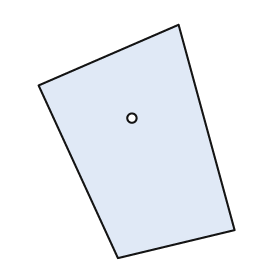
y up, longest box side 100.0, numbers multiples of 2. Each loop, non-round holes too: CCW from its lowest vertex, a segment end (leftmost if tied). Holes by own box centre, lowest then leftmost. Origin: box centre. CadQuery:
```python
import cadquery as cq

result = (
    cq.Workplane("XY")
    .moveTo(-8.0, -50.0)
    .lineTo(42.0, -38.0)
    .lineTo(18.0, 50.0)
    .lineTo(-42.0, 24.0)
    .close()
    .moveTo(-2.0, 10.0)
    .circle(2.0)
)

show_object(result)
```